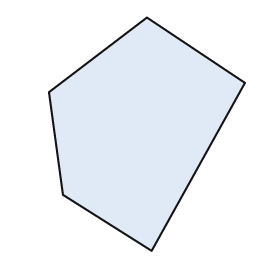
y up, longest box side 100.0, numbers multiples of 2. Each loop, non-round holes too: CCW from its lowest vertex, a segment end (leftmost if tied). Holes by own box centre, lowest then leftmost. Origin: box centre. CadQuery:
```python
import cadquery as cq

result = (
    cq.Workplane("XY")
    .moveTo(2.0, -50.0)
    .lineTo(42.0, 22.0)
    .lineTo(0.0, 50.0)
    .lineTo(-42.0, 18.0)
    .lineTo(-36.0, -26.0)
    .close()
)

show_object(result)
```